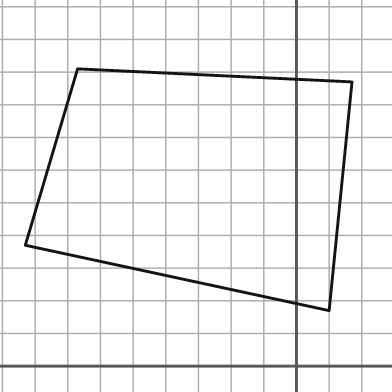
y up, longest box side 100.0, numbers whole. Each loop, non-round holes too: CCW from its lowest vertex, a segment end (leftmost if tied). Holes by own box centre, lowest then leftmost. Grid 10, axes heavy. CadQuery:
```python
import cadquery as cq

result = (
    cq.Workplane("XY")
    .moveTo(10.0, 17.0)
    .lineTo(17.0, 87.0)
    .lineTo(-67.0, 91.0)
    .lineTo(-83.0, 37.0)
    .close()
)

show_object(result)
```